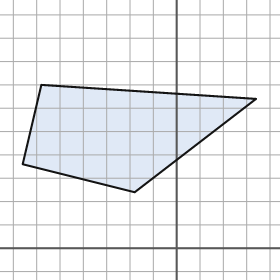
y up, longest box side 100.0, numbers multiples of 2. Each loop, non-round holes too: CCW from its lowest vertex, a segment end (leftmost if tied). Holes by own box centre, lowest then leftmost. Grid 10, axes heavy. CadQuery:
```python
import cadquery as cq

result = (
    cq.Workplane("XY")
    .moveTo(-18.0, 24.0)
    .lineTo(34.0, 64.0)
    .lineTo(-58.0, 70.0)
    .lineTo(-66.0, 36.0)
    .close()
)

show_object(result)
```